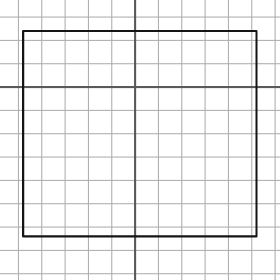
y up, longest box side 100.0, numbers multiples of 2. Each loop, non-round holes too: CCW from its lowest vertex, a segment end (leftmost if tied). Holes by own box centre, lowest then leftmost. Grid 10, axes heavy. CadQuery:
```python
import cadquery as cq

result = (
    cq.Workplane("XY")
    .moveTo(-48.0, -64.0)
    .lineTo(52.0, -64.0)
    .lineTo(52.0, 24.0)
    .lineTo(-48.0, 24.0)
    .close()
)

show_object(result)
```